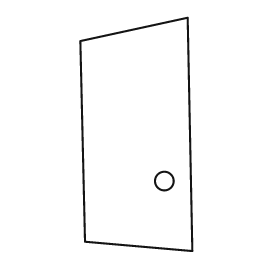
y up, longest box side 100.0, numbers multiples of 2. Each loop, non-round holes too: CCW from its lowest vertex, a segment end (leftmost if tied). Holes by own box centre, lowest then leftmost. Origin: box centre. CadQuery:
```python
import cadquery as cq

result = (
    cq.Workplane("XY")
    .moveTo(24.0, -50.0)
    .lineTo(22.0, 50.0)
    .lineTo(-24.0, 40.0)
    .lineTo(-22.0, -46.0)
    .close()
    .moveTo(12.0, -20.0)
    .circle(4.0)
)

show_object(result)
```